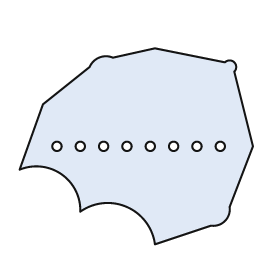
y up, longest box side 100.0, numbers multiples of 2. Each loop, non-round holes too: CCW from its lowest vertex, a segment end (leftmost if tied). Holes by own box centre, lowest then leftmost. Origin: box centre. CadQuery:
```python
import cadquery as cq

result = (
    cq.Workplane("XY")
    .moveTo(8.0, -42.0)
    .lineTo(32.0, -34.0)
    .threePointArc((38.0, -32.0), (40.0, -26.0))
    .lineTo(50.0, 0.0)
    .lineTo(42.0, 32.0)
    .threePointArc((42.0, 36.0), (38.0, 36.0))
    .lineTo(8.0, 42.0)
    .lineTo(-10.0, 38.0)
    .threePointArc((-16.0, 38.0), (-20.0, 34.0))
    .lineTo(-40.0, 18.0)
    .lineTo(-50.0, -10.0)
    .threePointArc((-32.0, -12.0), (-24.0, -28.0))
    .threePointArc((-4.0, -26.0), (8.0, -42.0))
    .close()
    .moveTo(-34.0, 0.0)
    .circle(2.0)
    .moveTo(-24.0, 0.0)
    .circle(2.0)
    .moveTo(-14.0, 0.0)
    .circle(2.0)
    .moveTo(-4.0, 0.0)
    .circle(2.0)
    .moveTo(6.0, 0.0)
    .circle(2.0)
    .moveTo(16.0, 0.0)
    .circle(2.0)
    .moveTo(26.0, 0.0)
    .circle(2.0)
    .moveTo(36.0, 0.0)
    .circle(2.0)
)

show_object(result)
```